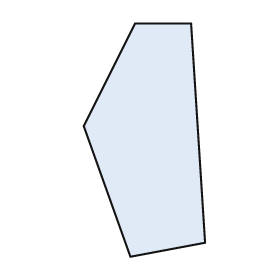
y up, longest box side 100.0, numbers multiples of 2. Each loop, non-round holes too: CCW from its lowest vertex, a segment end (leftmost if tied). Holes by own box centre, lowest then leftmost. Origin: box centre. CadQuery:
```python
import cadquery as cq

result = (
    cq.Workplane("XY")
    .moveTo(-6.0, -50.0)
    .lineTo(26.0, -44.0)
    .lineTo(20.0, 50.0)
    .lineTo(-4.0, 50.0)
    .lineTo(-26.0, 6.0)
    .close()
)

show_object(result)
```